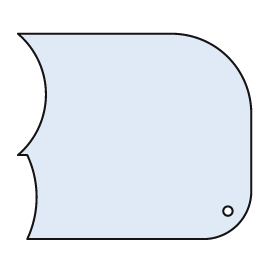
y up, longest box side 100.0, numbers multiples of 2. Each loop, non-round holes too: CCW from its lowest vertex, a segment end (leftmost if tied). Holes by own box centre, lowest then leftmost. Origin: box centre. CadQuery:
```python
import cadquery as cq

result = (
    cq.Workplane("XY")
    .moveTo(-46.0, -44.0)
    .lineTo(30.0, -44.0)
    .threePointArc((44.0, -38.0), (50.0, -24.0))
    .lineTo(50.0, 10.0)
    .threePointArc((40.0, 34.0), (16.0, 44.0))
    .lineTo(-50.0, 44.0)
    .threePointArc((-38.0, 18.0), (-50.0, -8.0))
    .lineTo(-46.0, -8.0)
    .threePointArc((-42.0, -26.0), (-46.0, -44.0))
    .close()
    .moveTo(40.0, -32.0)
    .circle(2.0)
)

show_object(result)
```